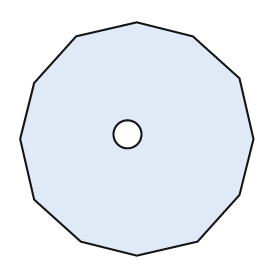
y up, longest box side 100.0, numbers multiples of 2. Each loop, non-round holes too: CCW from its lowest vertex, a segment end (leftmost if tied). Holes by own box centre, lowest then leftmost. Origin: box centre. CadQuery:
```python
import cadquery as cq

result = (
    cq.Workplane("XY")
    .moveTo(0.0, -50.0)
    .lineTo(26.0, -44.0)
    .lineTo(44.0, -24.0)
    .lineTo(50.0, 0.0)
    .lineTo(44.0, 26.0)
    .lineTo(24.0, 44.0)
    .lineTo(0.0, 50.0)
    .lineTo(-26.0, 44.0)
    .lineTo(-44.0, 24.0)
    .lineTo(-50.0, 0.0)
    .lineTo(-44.0, -26.0)
    .lineTo(-24.0, -44.0)
    .close()
    .moveTo(-4.0, 2.0)
    .circle(6.0)
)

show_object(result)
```